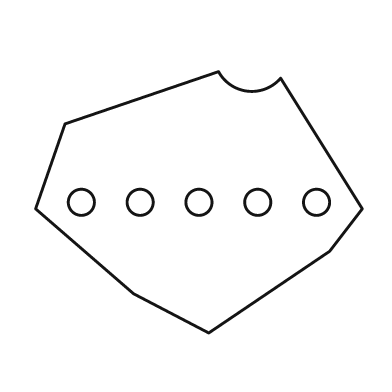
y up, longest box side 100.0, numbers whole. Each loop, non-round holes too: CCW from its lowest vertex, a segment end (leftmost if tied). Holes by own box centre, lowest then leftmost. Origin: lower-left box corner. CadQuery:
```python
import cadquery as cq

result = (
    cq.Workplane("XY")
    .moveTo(53.0, 0.0)
    .lineTo(90.0, 25.0)
    .lineTo(100.0, 38.0)
    .lineTo(75.0, 78.0)
    .threePointArc((65.0, 74.0), (56.0, 80.0))
    .lineTo(9.0, 64.0)
    .lineTo(0.0, 38.0)
    .lineTo(30.0, 12.0)
    .close()
    .moveTo(14.0, 40.0)
    .circle(4.0)
    .moveTo(32.0, 40.0)
    .circle(4.0)
    .moveTo(50.0, 40.0)
    .circle(4.0)
    .moveTo(68.0, 40.0)
    .circle(4.0)
    .moveTo(86.0, 40.0)
    .circle(4.0)
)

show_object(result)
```